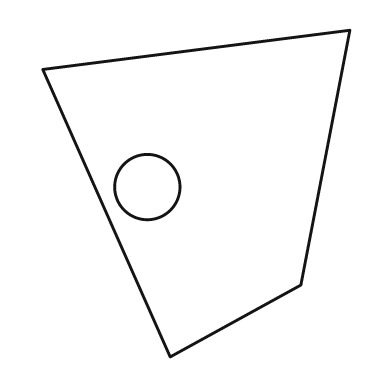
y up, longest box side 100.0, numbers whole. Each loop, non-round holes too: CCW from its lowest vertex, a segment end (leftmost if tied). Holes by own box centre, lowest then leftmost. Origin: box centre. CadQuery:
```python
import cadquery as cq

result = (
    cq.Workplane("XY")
    .moveTo(-8.0, -50.0)
    .lineTo(32.0, -28.0)
    .lineTo(47.0, 50.0)
    .lineTo(-47.0, 38.0)
    .close()
    .moveTo(-15.0, 2.0)
    .circle(10.0)
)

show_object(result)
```